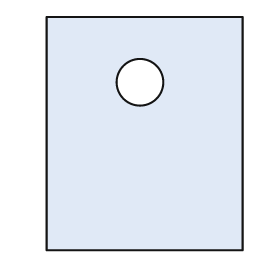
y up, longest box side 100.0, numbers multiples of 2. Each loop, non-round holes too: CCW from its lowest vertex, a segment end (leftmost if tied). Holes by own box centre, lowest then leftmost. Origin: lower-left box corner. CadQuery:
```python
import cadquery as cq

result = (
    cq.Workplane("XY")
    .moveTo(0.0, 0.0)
    .lineTo(84.0, 0.0)
    .lineTo(84.0, 100.0)
    .lineTo(0.0, 100.0)
    .close()
    .moveTo(40.0, 72.0)
    .circle(10.0)
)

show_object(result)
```